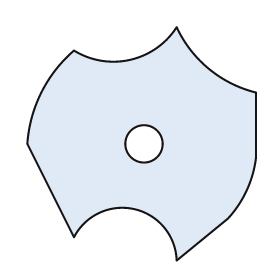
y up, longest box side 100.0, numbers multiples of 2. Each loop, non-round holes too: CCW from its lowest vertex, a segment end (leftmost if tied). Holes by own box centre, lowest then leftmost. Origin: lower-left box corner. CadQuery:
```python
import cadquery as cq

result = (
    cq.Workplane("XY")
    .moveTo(64.0, 0.0)
    .lineTo(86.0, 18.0)
    .threePointArc((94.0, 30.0), (98.0, 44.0))
    .lineTo(98.0, 72.0)
    .threePointArc((78.0, 82.0), (64.0, 100.0))
    .threePointArc((44.0, 86.0), (20.0, 90.0))
    .threePointArc((6.0, 72.0), (0.0, 50.0))
    .lineTo(20.0, 10.0)
    .threePointArc((46.0, 22.0), (64.0, 0.0))
    .close()
    .moveTo(50.0, 50.0)
    .circle(8.0)
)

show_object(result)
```